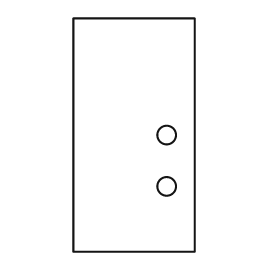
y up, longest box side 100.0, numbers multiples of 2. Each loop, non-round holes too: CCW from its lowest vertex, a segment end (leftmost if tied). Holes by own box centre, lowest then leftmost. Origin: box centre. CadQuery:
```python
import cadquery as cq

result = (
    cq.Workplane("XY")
    .moveTo(-26.0, -50.0)
    .lineTo(26.0, -50.0)
    .lineTo(26.0, 50.0)
    .lineTo(-26.0, 50.0)
    .close()
    .moveTo(14.0, -22.0)
    .circle(4.0)
    .moveTo(14.0, 0.0)
    .circle(4.0)
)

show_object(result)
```